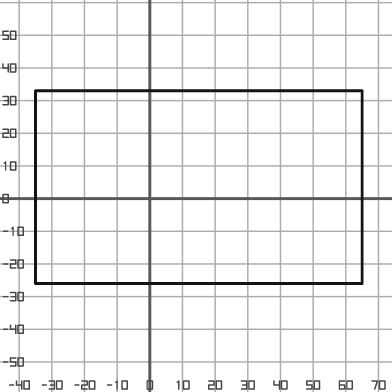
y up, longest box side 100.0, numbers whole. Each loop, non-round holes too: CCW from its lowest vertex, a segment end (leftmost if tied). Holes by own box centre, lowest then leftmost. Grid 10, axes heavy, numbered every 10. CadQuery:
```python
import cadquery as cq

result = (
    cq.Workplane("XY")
    .moveTo(-35.0, -26.0)
    .lineTo(65.0, -26.0)
    .lineTo(65.0, 33.0)
    .lineTo(-35.0, 33.0)
    .close()
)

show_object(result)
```